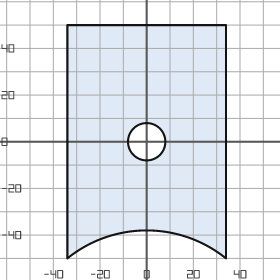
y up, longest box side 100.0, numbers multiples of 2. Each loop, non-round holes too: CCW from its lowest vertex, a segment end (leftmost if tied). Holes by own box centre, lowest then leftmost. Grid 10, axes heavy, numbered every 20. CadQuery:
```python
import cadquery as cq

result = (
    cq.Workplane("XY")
    .moveTo(-34.0, -50.0)
    .threePointArc((0.0, -38.0), (34.0, -50.0))
    .lineTo(34.0, 50.0)
    .lineTo(-34.0, 50.0)
    .close()
    .moveTo(0.0, 0.0)
    .circle(8.0)
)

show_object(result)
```